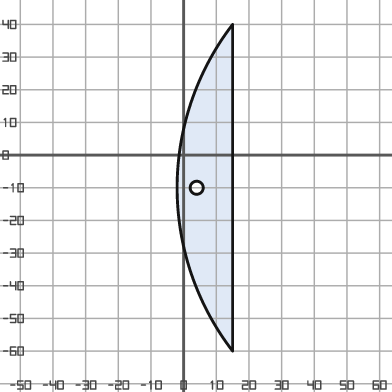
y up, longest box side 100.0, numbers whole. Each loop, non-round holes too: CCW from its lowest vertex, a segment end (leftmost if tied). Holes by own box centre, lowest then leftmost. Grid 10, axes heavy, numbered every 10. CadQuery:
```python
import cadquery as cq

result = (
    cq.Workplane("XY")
    .moveTo(15.0, -60.0)
    .lineTo(15.0, 40.0)
    .threePointArc((-2.0, -10.0), (15.0, -60.0))
    .close()
    .moveTo(4.0, -10.0)
    .circle(2.0)
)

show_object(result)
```